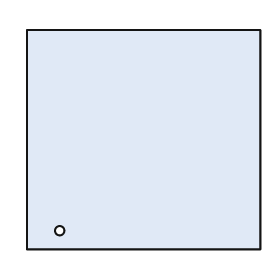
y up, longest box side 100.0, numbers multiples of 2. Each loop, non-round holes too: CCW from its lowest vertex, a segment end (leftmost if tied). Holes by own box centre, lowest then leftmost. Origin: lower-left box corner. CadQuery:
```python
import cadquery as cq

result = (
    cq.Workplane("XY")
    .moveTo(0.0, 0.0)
    .lineTo(100.0, 0.0)
    .lineTo(100.0, 94.0)
    .lineTo(0.0, 94.0)
    .close()
    .moveTo(14.0, 8.0)
    .circle(2.0)
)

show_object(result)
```